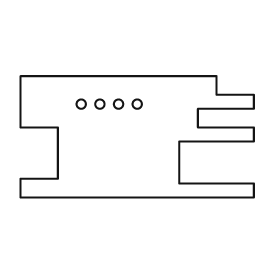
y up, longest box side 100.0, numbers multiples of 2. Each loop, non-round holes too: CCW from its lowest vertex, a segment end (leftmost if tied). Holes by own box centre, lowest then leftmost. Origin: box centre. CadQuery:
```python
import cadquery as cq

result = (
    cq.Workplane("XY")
    .moveTo(-50.0, -26.0)
    .lineTo(50.0, -26.0)
    .lineTo(50.0, -20.0)
    .lineTo(18.0, -20.0)
    .lineTo(18.0, -2.0)
    .lineTo(50.0, -2.0)
    .lineTo(50.0, 4.0)
    .lineTo(26.0, 4.0)
    .lineTo(26.0, 12.0)
    .lineTo(50.0, 12.0)
    .lineTo(50.0, 18.0)
    .lineTo(34.0, 18.0)
    .lineTo(34.0, 26.0)
    .lineTo(-50.0, 26.0)
    .lineTo(-50.0, 4.0)
    .lineTo(-34.0, 4.0)
    .lineTo(-34.0, -18.0)
    .lineTo(-50.0, -18.0)
    .close()
    .moveTo(-24.0, 14.0)
    .circle(2.0)
    .moveTo(-16.0, 14.0)
    .circle(2.0)
    .moveTo(-8.0, 14.0)
    .circle(2.0)
    .moveTo(0.0, 14.0)
    .circle(2.0)
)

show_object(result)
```